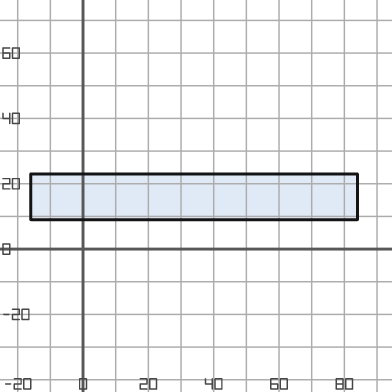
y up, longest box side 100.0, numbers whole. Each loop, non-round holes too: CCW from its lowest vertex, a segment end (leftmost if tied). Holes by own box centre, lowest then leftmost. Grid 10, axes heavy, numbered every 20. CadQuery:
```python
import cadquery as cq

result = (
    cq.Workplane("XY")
    .moveTo(-16.0, 9.0)
    .lineTo(84.0, 9.0)
    .lineTo(84.0, 23.0)
    .lineTo(-16.0, 23.0)
    .close()
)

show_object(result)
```